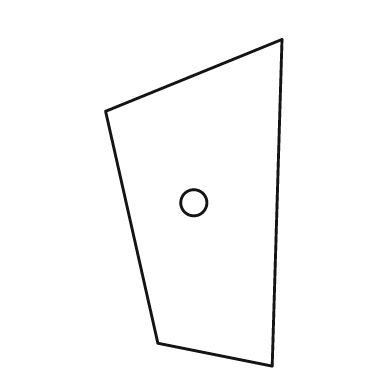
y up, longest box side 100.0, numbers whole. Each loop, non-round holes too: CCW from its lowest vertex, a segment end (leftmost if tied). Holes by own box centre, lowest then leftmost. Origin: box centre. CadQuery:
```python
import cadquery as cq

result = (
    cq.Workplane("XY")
    .moveTo(24.0, -50.0)
    .lineTo(27.0, 50.0)
    .lineTo(-27.0, 28.0)
    .lineTo(-11.0, -43.0)
    .close()
    .moveTo(0.0, 0.0)
    .circle(4.0)
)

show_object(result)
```